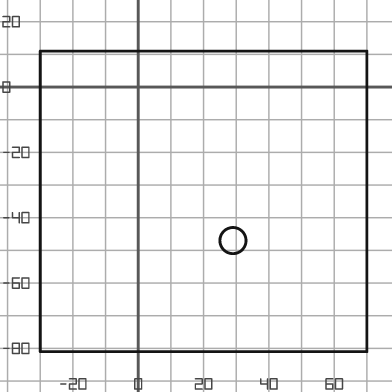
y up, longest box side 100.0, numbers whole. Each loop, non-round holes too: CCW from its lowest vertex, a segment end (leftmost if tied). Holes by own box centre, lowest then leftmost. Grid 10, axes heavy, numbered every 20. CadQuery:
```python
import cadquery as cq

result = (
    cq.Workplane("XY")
    .moveTo(-30.0, -81.0)
    .lineTo(70.0, -81.0)
    .lineTo(70.0, 11.0)
    .lineTo(-30.0, 11.0)
    .close()
    .moveTo(29.0, -47.0)
    .circle(4.0)
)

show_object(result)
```